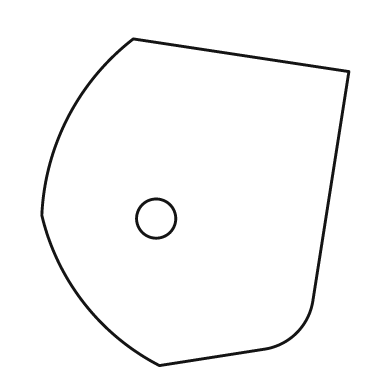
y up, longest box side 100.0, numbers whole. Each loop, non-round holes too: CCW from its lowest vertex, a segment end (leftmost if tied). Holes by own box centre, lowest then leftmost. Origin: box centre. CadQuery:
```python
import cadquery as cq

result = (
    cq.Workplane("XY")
    .moveTo(-11.0, -50.0)
    .lineTo(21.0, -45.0)
    .threePointArc((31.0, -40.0), (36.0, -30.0))
    .lineTo(47.0, 40.0)
    .lineTo(-19.0, 50.0)
    .threePointArc((-39.0, 26.0), (-47.0, -4.0))
    .threePointArc((-34.0, -31.0), (-11.0, -50.0))
    .close()
    .moveTo(-12.0, -5.0)
    .circle(6.0)
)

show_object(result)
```